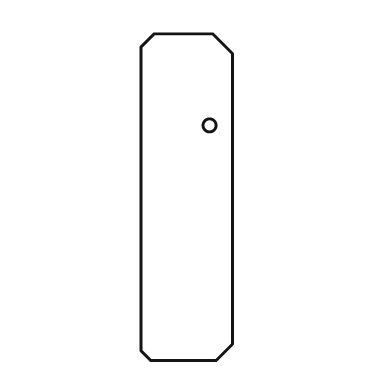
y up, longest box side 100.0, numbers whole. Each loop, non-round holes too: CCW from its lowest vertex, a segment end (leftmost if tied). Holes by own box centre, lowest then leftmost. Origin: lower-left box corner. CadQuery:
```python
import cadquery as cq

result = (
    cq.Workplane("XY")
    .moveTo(3.0, 0.0)
    .lineTo(23.0, 0.0)
    .lineTo(28.0, 5.0)
    .lineTo(28.0, 94.0)
    .lineTo(22.0, 100.0)
    .lineTo(4.0, 100.0)
    .lineTo(0.0, 96.0)
    .lineTo(0.0, 3.0)
    .close()
    .moveTo(21.0, 72.0)
    .circle(2.0)
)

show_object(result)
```